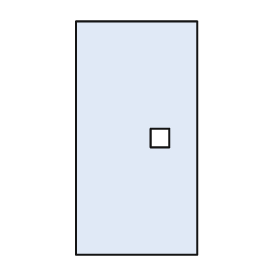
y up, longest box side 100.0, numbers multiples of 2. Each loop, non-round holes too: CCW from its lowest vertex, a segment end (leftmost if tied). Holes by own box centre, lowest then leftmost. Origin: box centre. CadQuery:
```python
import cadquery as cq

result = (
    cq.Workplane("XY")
    .moveTo(-26.0, -50.0)
    .lineTo(26.0, -50.0)
    .lineTo(26.0, 50.0)
    .lineTo(-26.0, 50.0)
    .close()
    .moveTo(6.0, -4.0)
    .lineTo(14.0, -4.0)
    .lineTo(14.0, 4.0)
    .lineTo(6.0, 4.0)
    .close()
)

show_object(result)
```